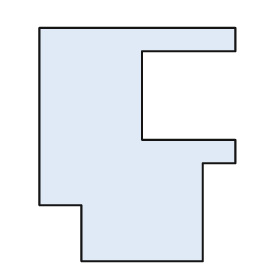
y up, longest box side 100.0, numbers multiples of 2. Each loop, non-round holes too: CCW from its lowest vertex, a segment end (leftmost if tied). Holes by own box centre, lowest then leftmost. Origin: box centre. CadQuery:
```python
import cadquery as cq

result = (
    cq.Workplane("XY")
    .moveTo(-24.0, -50.0)
    .lineTo(28.0, -50.0)
    .lineTo(28.0, -8.0)
    .lineTo(42.0, -8.0)
    .lineTo(42.0, 2.0)
    .lineTo(2.0, 2.0)
    .lineTo(2.0, 40.0)
    .lineTo(42.0, 40.0)
    .lineTo(42.0, 50.0)
    .lineTo(-42.0, 50.0)
    .lineTo(-42.0, -26.0)
    .lineTo(-24.0, -26.0)
    .close()
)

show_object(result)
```